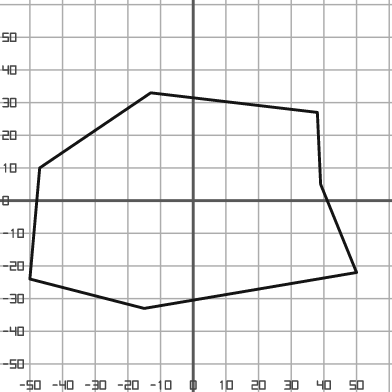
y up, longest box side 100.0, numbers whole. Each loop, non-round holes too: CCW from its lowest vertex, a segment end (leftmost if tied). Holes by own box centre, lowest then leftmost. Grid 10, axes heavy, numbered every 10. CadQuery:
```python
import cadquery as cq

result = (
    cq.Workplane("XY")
    .moveTo(-15.0, -33.0)
    .lineTo(50.0, -22.0)
    .lineTo(39.0, 5.0)
    .lineTo(38.0, 27.0)
    .lineTo(-13.0, 33.0)
    .lineTo(-47.0, 10.0)
    .lineTo(-50.0, -24.0)
    .close()
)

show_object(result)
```